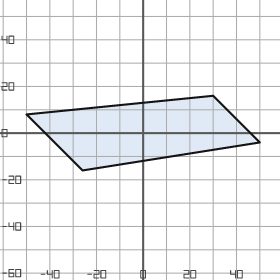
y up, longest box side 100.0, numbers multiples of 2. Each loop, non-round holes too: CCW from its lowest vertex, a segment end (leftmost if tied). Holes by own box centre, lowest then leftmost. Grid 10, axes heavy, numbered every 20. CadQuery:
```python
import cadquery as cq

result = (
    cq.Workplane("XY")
    .moveTo(-26.0, -16.0)
    .lineTo(50.0, -4.0)
    .lineTo(30.0, 16.0)
    .lineTo(-50.0, 8.0)
    .close()
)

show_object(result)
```